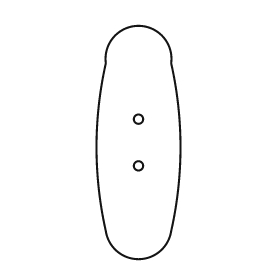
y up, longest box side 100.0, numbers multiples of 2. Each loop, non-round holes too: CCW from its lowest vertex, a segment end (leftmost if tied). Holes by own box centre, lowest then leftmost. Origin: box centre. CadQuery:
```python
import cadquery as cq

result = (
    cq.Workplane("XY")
    .moveTo(-14.0, -38.0)
    .threePointArc((0.0, -50.0), (14.0, -38.0))
    .threePointArc((18.0, -2.0), (14.0, 34.0))
    .threePointArc((0.0, 50.0), (-14.0, 34.0))
    .threePointArc((-18.0, -2.0), (-14.0, -38.0))
    .close()
    .moveTo(0.0, -10.0)
    .circle(2.0)
    .moveTo(0.0, 10.0)
    .circle(2.0)
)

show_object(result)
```